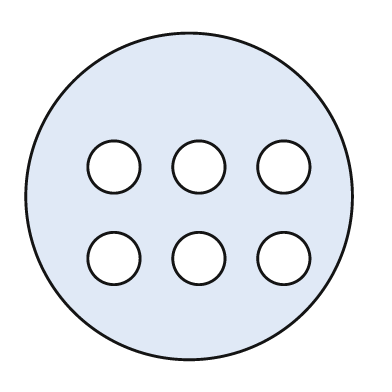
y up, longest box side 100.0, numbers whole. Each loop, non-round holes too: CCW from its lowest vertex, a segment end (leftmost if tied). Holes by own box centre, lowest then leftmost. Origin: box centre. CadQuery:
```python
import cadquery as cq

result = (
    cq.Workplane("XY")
    .moveTo(0.0, 0.0)
    .circle(50.0)
    .moveTo(-23.0, -19.0)
    .circle(8.0)
    .moveTo(3.0, -19.0)
    .circle(8.0)
    .moveTo(29.0, -19.0)
    .circle(8.0)
    .moveTo(-23.0, 9.0)
    .circle(8.0)
    .moveTo(3.0, 9.0)
    .circle(8.0)
    .moveTo(29.0, 9.0)
    .circle(8.0)
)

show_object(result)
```